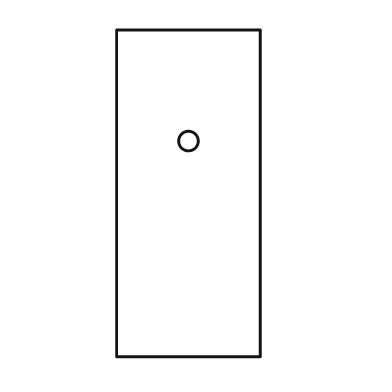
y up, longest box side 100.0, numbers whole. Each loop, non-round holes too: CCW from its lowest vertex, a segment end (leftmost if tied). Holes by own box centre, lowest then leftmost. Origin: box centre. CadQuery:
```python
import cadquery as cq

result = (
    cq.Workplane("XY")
    .moveTo(-22.0, -50.0)
    .lineTo(22.0, -50.0)
    .lineTo(22.0, 50.0)
    .lineTo(-22.0, 50.0)
    .close()
    .moveTo(0.0, 16.0)
    .circle(3.0)
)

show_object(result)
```